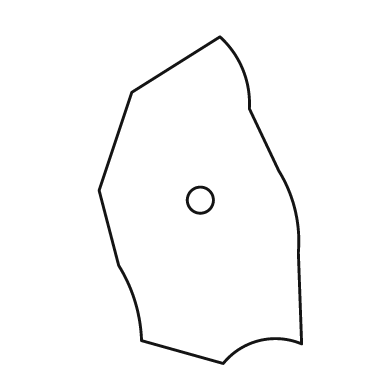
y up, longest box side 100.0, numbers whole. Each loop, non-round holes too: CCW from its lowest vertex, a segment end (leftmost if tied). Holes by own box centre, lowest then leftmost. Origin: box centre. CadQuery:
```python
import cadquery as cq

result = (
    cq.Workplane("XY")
    .moveTo(7.0, -50.0)
    .threePointArc((18.0, -43.0), (31.0, -44.0))
    .lineTo(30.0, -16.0)
    .threePointArc((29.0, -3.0), (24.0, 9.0))
    .lineTo(15.0, 28.0)
    .threePointArc((13.0, 40.0), (6.0, 50.0))
    .lineTo(-21.0, 33.0)
    .lineTo(-31.0, 3.0)
    .lineTo(-25.0, -20.0)
    .threePointArc((-20.0, -31.0), (-18.0, -43.0))
    .close()
    .moveTo(0.0, 0.0)
    .circle(4.0)
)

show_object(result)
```